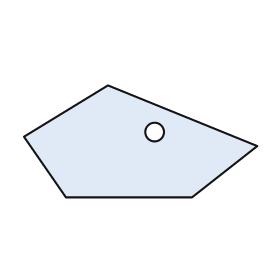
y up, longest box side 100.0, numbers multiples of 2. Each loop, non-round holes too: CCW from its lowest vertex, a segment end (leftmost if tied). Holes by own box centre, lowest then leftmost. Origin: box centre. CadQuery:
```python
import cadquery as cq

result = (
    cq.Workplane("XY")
    .moveTo(-32.0, -24.0)
    .lineTo(22.0, -24.0)
    .lineTo(50.0, -2.0)
    .lineTo(-14.0, 24.0)
    .lineTo(-50.0, 2.0)
    .close()
    .moveTo(6.0, 4.0)
    .circle(4.0)
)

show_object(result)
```